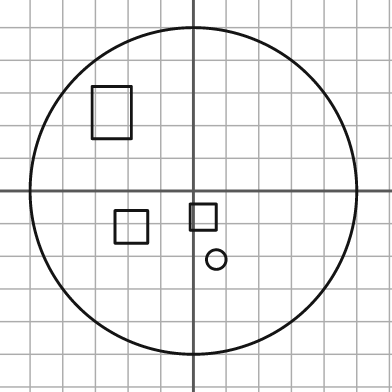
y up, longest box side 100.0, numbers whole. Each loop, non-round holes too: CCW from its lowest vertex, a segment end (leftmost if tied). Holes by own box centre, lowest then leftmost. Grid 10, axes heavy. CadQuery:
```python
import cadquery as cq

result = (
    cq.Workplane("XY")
    .moveTo(0.0, 0.0)
    .circle(50.0)
    .moveTo(7.0, -21.0)
    .circle(3.0)
    .moveTo(-24.0, -16.0)
    .lineTo(-14.0, -16.0)
    .lineTo(-14.0, -6.0)
    .lineTo(-24.0, -6.0)
    .close()
    .moveTo(-1.0, -12.0)
    .lineTo(7.0, -12.0)
    .lineTo(7.0, -4.0)
    .lineTo(-1.0, -4.0)
    .close()
    .moveTo(-31.0, 16.0)
    .lineTo(-19.0, 16.0)
    .lineTo(-19.0, 32.0)
    .lineTo(-31.0, 32.0)
    .close()
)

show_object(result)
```